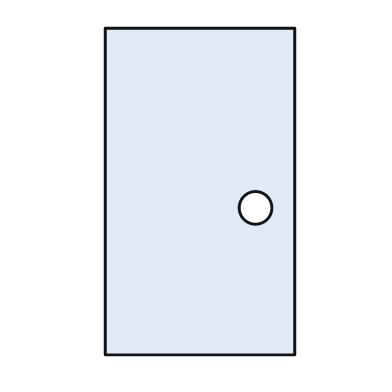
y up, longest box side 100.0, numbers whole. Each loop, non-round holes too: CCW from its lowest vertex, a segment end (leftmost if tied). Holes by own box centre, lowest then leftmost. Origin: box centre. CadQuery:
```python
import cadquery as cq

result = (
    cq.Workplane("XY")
    .moveTo(-29.0, -50.0)
    .lineTo(29.0, -50.0)
    .lineTo(29.0, 50.0)
    .lineTo(-29.0, 50.0)
    .close()
    .moveTo(17.0, -5.0)
    .circle(5.0)
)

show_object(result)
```